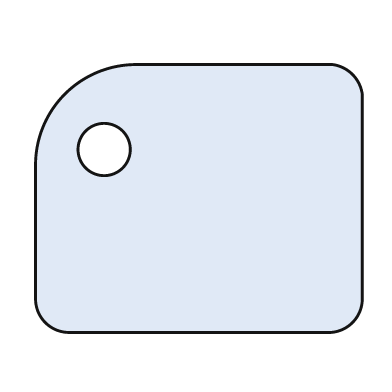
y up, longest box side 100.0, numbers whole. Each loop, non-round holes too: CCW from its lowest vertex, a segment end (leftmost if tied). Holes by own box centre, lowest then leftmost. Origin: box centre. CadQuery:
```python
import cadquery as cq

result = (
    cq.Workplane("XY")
    .moveTo(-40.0, -41.0)
    .lineTo(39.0, -41.0)
    .threePointArc((47.0, -38.0), (50.0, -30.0))
    .lineTo(50.0, 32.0)
    .threePointArc((47.0, 38.0), (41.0, 41.0))
    .lineTo(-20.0, 41.0)
    .threePointArc((-41.0, 32.0), (-50.0, 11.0))
    .lineTo(-50.0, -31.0)
    .threePointArc((-47.0, -38.0), (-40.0, -41.0))
    .close()
    .moveTo(-29.0, 15.0)
    .circle(8.0)
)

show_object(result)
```